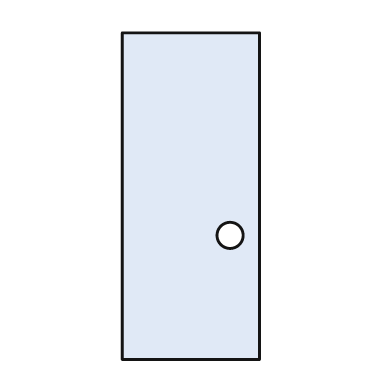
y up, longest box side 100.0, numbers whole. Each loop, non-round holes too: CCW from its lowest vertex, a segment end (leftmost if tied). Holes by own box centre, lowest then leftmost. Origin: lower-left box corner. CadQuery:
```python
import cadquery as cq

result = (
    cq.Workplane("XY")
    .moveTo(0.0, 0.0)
    .lineTo(42.0, 0.0)
    .lineTo(42.0, 100.0)
    .lineTo(0.0, 100.0)
    .close()
    .moveTo(33.0, 38.0)
    .circle(4.0)
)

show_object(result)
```